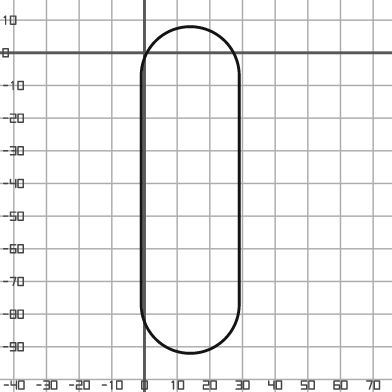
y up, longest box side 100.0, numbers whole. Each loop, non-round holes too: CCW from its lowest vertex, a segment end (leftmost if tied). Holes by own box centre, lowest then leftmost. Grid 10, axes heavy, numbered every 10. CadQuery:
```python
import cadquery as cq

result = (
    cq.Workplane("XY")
    .moveTo(-1.0, -77.0)
    .threePointArc((14.0, -92.0), (29.0, -77.0))
    .lineTo(29.0, -7.0)
    .threePointArc((14.0, 8.0), (-1.0, -7.0))
    .close()
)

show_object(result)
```